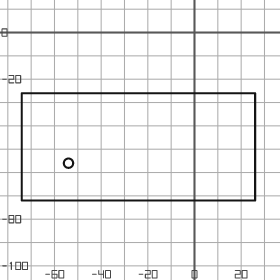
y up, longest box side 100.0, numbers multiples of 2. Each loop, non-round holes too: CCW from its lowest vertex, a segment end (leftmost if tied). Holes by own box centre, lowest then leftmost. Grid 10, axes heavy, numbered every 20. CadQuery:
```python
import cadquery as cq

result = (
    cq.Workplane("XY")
    .moveTo(-74.0, -72.0)
    .lineTo(26.0, -72.0)
    .lineTo(26.0, -26.0)
    .lineTo(-74.0, -26.0)
    .close()
    .moveTo(-54.0, -56.0)
    .circle(2.0)
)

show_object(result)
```